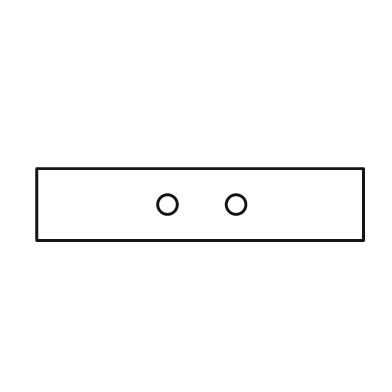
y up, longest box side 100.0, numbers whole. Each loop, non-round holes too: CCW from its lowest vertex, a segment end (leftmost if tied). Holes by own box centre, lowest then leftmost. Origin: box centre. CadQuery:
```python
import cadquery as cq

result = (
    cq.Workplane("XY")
    .moveTo(-50.0, -11.0)
    .lineTo(50.0, -11.0)
    .lineTo(50.0, 11.0)
    .lineTo(-50.0, 11.0)
    .close()
    .moveTo(-10.0, 0.0)
    .circle(3.0)
    .moveTo(11.0, 0.0)
    .circle(3.0)
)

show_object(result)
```